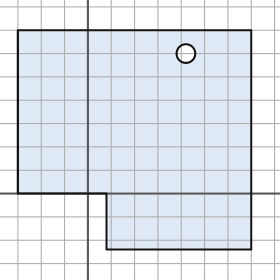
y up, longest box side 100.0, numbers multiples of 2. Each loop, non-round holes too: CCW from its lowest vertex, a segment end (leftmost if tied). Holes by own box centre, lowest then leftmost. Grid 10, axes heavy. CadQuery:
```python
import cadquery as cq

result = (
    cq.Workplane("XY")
    .moveTo(8.0, -24.0)
    .lineTo(70.0, -24.0)
    .lineTo(70.0, 70.0)
    .lineTo(-30.0, 70.0)
    .lineTo(-30.0, 0.0)
    .lineTo(8.0, 0.0)
    .close()
    .moveTo(42.0, 60.0)
    .circle(4.0)
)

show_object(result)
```